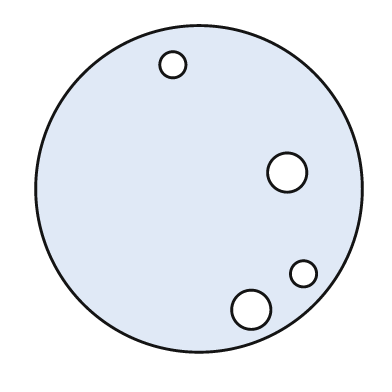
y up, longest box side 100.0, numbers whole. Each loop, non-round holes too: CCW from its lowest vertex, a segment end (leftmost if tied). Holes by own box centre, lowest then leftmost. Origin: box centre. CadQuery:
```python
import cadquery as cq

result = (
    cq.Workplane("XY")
    .moveTo(0.0, 0.0)
    .circle(50.0)
    .moveTo(16.0, -37.0)
    .circle(6.0)
    .moveTo(32.0, -26.0)
    .circle(4.0)
    .moveTo(27.0, 5.0)
    .circle(6.0)
    .moveTo(-8.0, 38.0)
    .circle(4.0)
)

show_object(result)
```